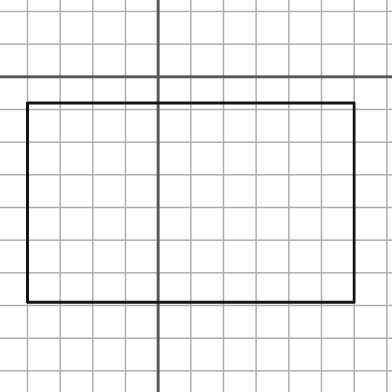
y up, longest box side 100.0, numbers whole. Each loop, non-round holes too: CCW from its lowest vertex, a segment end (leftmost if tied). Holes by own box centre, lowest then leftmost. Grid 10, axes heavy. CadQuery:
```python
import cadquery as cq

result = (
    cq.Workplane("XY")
    .moveTo(-40.0, -69.0)
    .lineTo(60.0, -69.0)
    .lineTo(60.0, -8.0)
    .lineTo(-40.0, -8.0)
    .close()
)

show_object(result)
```